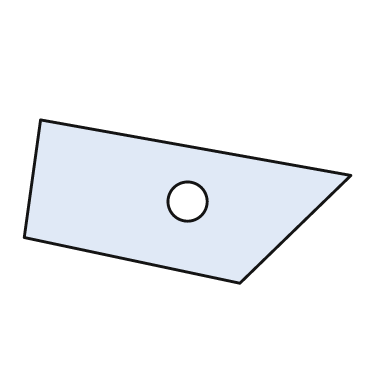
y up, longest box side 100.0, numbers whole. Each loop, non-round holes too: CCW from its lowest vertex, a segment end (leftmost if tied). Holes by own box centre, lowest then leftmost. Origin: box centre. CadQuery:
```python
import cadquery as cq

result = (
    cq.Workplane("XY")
    .moveTo(16.0, -25.0)
    .lineTo(50.0, 8.0)
    .lineTo(-45.0, 25.0)
    .lineTo(-50.0, -11.0)
    .close()
    .moveTo(0.0, 0.0)
    .circle(6.0)
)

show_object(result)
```